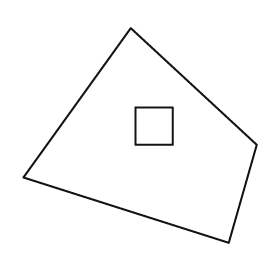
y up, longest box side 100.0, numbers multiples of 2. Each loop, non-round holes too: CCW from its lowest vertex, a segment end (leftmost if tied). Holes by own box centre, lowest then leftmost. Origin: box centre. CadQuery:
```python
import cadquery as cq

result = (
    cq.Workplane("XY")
    .moveTo(38.0, -46.0)
    .lineTo(50.0, -4.0)
    .lineTo(-4.0, 46.0)
    .lineTo(-50.0, -18.0)
    .close()
    .moveTo(-2.0, -4.0)
    .lineTo(14.0, -4.0)
    .lineTo(14.0, 12.0)
    .lineTo(-2.0, 12.0)
    .close()
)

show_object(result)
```